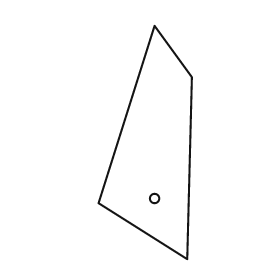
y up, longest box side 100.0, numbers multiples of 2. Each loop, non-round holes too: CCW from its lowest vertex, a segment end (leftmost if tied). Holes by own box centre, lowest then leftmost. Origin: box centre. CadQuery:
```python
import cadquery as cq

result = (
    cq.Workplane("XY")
    .moveTo(18.0, -50.0)
    .lineTo(20.0, 28.0)
    .lineTo(4.0, 50.0)
    .lineTo(-20.0, -26.0)
    .close()
    .moveTo(4.0, -24.0)
    .circle(2.0)
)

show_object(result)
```